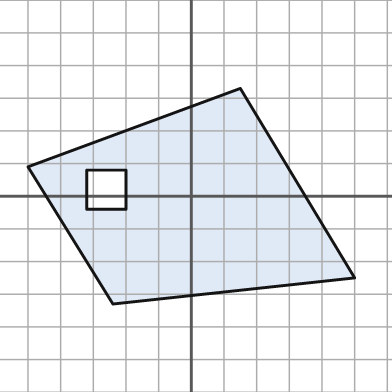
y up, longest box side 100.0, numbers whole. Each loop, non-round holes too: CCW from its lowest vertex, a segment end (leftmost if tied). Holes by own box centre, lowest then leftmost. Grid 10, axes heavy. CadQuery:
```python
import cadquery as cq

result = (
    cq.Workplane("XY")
    .moveTo(-24.0, -33.0)
    .lineTo(50.0, -25.0)
    .lineTo(15.0, 33.0)
    .lineTo(-50.0, 9.0)
    .close()
    .moveTo(-32.0, -4.0)
    .lineTo(-20.0, -4.0)
    .lineTo(-20.0, 8.0)
    .lineTo(-32.0, 8.0)
    .close()
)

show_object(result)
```